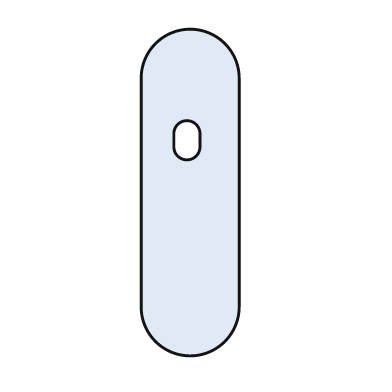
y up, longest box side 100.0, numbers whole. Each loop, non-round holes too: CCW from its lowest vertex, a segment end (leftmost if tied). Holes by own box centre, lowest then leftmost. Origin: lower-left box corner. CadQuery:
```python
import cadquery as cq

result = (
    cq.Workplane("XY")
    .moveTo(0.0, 15.0)
    .threePointArc((15.0, 0.0), (30.0, 15.0))
    .lineTo(30.0, 85.0)
    .threePointArc((15.0, 100.0), (0.0, 85.0))
    .close()
    .moveTo(10.0, 64.0)
    .threePointArc((14.0, 60.0), (18.0, 64.0))
    .lineTo(18.0, 68.0)
    .threePointArc((14.0, 72.0), (10.0, 68.0))
    .close()
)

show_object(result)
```